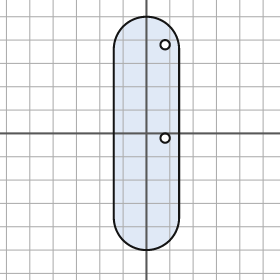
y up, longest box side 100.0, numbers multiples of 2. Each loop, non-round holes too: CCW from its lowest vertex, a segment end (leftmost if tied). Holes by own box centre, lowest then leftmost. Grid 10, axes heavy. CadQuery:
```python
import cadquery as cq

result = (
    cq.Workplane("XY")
    .moveTo(-14.0, -36.0)
    .threePointArc((0.0, -50.0), (14.0, -36.0))
    .lineTo(14.0, 36.0)
    .threePointArc((0.0, 50.0), (-14.0, 36.0))
    .close()
    .moveTo(8.0, -2.0)
    .circle(2.0)
    .moveTo(8.0, 38.0)
    .circle(2.0)
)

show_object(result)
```